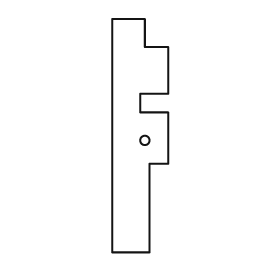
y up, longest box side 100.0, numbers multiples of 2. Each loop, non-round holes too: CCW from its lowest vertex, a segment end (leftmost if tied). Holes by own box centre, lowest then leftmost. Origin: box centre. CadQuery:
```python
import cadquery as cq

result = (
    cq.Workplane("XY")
    .moveTo(-12.0, -50.0)
    .lineTo(4.0, -50.0)
    .lineTo(4.0, -12.0)
    .lineTo(12.0, -12.0)
    .lineTo(12.0, 10.0)
    .lineTo(0.0, 10.0)
    .lineTo(0.0, 18.0)
    .lineTo(12.0, 18.0)
    .lineTo(12.0, 38.0)
    .lineTo(2.0, 38.0)
    .lineTo(2.0, 50.0)
    .lineTo(-12.0, 50.0)
    .close()
    .moveTo(2.0, -2.0)
    .circle(2.0)
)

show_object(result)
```